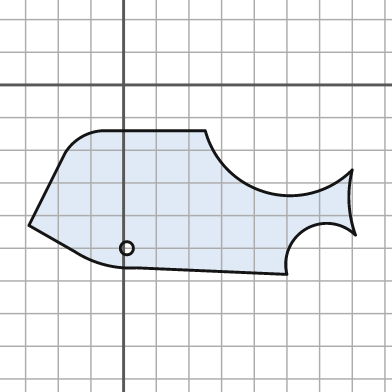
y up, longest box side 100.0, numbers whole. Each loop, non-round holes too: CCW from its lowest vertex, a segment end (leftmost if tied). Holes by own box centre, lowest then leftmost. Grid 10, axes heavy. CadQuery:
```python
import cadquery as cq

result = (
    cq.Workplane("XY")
    .moveTo(50.0, -58.0)
    .threePointArc((56.0, -44.0), (71.0, -46.0))
    .threePointArc((69.0, -36.0), (70.0, -26.0))
    .threePointArc((44.0, -33.0), (25.0, -14.0))
    .lineTo(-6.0, -14.0)
    .threePointArc((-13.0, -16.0), (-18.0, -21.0))
    .lineTo(-29.0, -43.0)
    .lineTo(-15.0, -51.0)
    .threePointArc((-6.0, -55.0), (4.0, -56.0))
    .close()
    .moveTo(1.0, -50.0)
    .circle(2.0)
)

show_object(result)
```